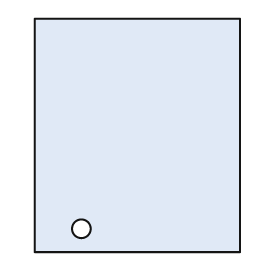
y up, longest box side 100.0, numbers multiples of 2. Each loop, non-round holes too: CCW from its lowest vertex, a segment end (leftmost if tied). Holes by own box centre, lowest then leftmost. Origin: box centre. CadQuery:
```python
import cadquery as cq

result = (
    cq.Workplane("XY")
    .moveTo(-44.0, -50.0)
    .lineTo(44.0, -50.0)
    .lineTo(44.0, 50.0)
    .lineTo(-44.0, 50.0)
    .close()
    .moveTo(-24.0, -40.0)
    .circle(4.0)
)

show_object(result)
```